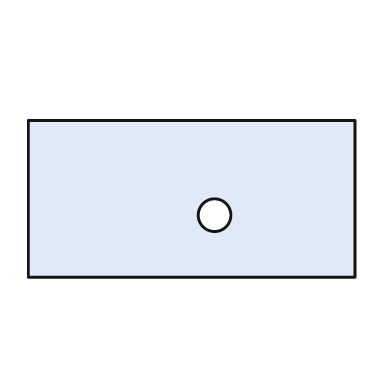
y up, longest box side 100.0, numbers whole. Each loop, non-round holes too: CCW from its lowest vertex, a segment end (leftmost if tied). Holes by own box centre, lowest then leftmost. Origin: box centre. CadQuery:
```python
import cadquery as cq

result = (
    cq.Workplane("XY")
    .moveTo(-50.0, -24.0)
    .lineTo(50.0, -24.0)
    .lineTo(50.0, 24.0)
    .lineTo(-50.0, 24.0)
    .close()
    .moveTo(7.0, -5.0)
    .circle(5.0)
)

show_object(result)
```